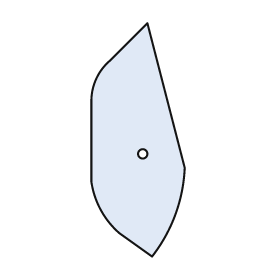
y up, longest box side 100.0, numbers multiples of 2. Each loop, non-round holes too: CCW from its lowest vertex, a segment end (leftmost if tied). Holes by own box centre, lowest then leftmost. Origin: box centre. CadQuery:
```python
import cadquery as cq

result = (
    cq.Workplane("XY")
    .moveTo(6.0, -50.0)
    .threePointArc((16.0, -32.0), (20.0, -12.0))
    .lineTo(4.0, 50.0)
    .lineTo(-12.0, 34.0)
    .threePointArc((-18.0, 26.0), (-20.0, 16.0))
    .lineTo(-20.0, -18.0)
    .threePointArc((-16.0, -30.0), (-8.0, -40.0))
    .close()
    .moveTo(2.0, -6.0)
    .circle(2.0)
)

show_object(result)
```